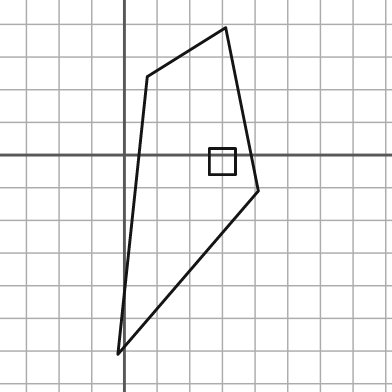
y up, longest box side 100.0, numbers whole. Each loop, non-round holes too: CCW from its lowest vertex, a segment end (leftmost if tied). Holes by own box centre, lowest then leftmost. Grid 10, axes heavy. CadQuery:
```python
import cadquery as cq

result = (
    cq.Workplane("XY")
    .moveTo(-2.0, -61.0)
    .lineTo(41.0, -11.0)
    .lineTo(31.0, 39.0)
    .lineTo(7.0, 24.0)
    .close()
    .moveTo(26.0, -6.0)
    .lineTo(34.0, -6.0)
    .lineTo(34.0, 2.0)
    .lineTo(26.0, 2.0)
    .close()
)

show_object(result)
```